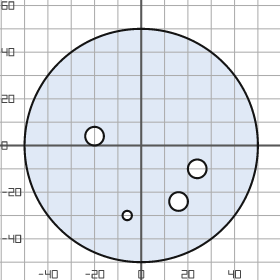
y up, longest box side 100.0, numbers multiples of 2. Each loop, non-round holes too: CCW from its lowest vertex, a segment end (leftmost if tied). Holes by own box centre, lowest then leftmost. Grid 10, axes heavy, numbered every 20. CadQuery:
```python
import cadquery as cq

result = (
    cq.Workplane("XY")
    .moveTo(0.0, 0.0)
    .circle(50.0)
    .moveTo(-6.0, -30.0)
    .circle(2.0)
    .moveTo(16.0, -24.0)
    .circle(4.0)
    .moveTo(24.0, -10.0)
    .circle(4.0)
    .moveTo(-20.0, 4.0)
    .circle(4.0)
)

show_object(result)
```